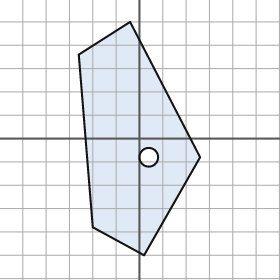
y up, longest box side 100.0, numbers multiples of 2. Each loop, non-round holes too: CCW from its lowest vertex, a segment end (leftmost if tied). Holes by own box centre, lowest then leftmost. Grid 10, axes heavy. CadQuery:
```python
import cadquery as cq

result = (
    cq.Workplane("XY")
    .moveTo(2.0, -50.0)
    .lineTo(26.0, -8.0)
    .lineTo(-4.0, 50.0)
    .lineTo(-26.0, 36.0)
    .lineTo(-20.0, -38.0)
    .close()
    .moveTo(4.0, -8.0)
    .circle(4.0)
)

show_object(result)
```